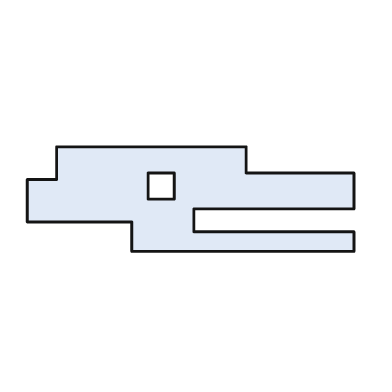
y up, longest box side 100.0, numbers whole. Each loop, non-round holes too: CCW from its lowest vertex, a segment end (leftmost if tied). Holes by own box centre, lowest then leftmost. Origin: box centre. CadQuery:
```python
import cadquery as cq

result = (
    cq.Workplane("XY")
    .moveTo(-18.0, -16.0)
    .lineTo(50.0, -16.0)
    .lineTo(50.0, -10.0)
    .lineTo(1.0, -10.0)
    .lineTo(1.0, -3.0)
    .lineTo(50.0, -3.0)
    .lineTo(50.0, 8.0)
    .lineTo(17.0, 8.0)
    .lineTo(17.0, 16.0)
    .lineTo(-41.0, 16.0)
    .lineTo(-41.0, 6.0)
    .lineTo(-50.0, 6.0)
    .lineTo(-50.0, -7.0)
    .lineTo(-18.0, -7.0)
    .close()
    .moveTo(-13.0, 0.0)
    .lineTo(-5.0, 0.0)
    .lineTo(-5.0, 8.0)
    .lineTo(-13.0, 8.0)
    .close()
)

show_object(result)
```